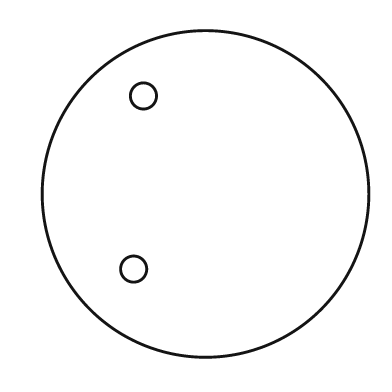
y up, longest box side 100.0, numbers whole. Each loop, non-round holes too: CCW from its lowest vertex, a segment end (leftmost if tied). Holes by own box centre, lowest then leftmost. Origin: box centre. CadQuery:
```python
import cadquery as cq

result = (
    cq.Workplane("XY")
    .moveTo(0.0, 0.0)
    .circle(50.0)
    .moveTo(-22.0, -23.0)
    .circle(4.0)
    .moveTo(-19.0, 30.0)
    .circle(4.0)
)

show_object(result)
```